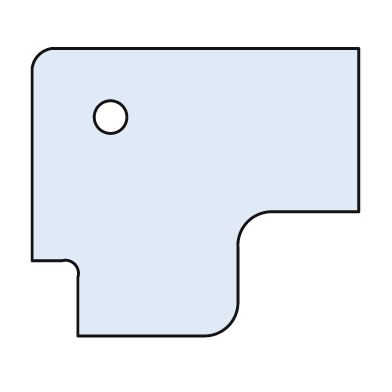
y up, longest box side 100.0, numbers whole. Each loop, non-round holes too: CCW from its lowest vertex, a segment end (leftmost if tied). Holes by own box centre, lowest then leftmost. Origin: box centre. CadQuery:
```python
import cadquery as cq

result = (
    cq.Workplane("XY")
    .moveTo(-36.0, -44.0)
    .lineTo(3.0, -44.0)
    .threePointArc((10.0, -41.0), (13.0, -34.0))
    .lineTo(13.0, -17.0)
    .threePointArc((16.0, -9.0), (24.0, -6.0))
    .lineTo(50.0, -6.0)
    .lineTo(50.0, 44.0)
    .lineTo(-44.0, 44.0)
    .threePointArc((-48.0, 42.0), (-50.0, 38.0))
    .lineTo(-50.0, -21.0)
    .lineTo(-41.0, -21.0)
    .threePointArc((-37.0, -22.0), (-36.0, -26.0))
    .close()
    .moveTo(-26.0, 23.0)
    .circle(5.0)
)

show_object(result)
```